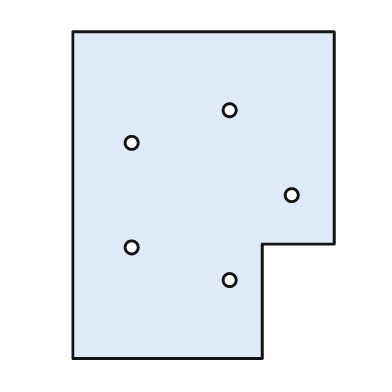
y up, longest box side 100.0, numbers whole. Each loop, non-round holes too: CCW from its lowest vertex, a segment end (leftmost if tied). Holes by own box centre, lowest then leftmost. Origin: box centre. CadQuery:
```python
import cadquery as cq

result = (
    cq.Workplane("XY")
    .moveTo(-40.0, -50.0)
    .lineTo(18.0, -50.0)
    .lineTo(18.0, -15.0)
    .lineTo(40.0, -15.0)
    .lineTo(40.0, 50.0)
    .lineTo(-40.0, 50.0)
    .close()
    .moveTo(8.0, -26.0)
    .circle(2.0)
    .moveTo(-22.0, -16.0)
    .circle(2.0)
    .moveTo(27.0, 0.0)
    .circle(2.0)
    .moveTo(-22.0, 16.0)
    .circle(2.0)
    .moveTo(8.0, 26.0)
    .circle(2.0)
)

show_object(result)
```